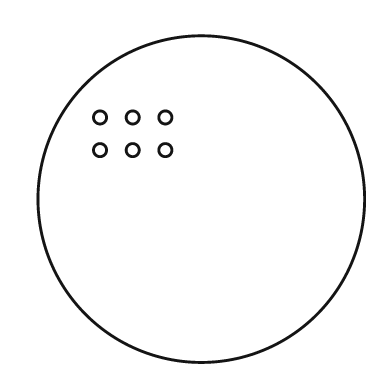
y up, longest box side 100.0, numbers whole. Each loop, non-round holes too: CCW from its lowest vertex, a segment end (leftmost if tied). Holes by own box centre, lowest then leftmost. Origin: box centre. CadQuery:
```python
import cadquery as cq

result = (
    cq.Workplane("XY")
    .moveTo(0.0, 0.0)
    .circle(50.0)
    .moveTo(-31.0, 15.0)
    .circle(2.0)
    .moveTo(-21.0, 15.0)
    .circle(2.0)
    .moveTo(-11.0, 15.0)
    .circle(2.0)
    .moveTo(-31.0, 25.0)
    .circle(2.0)
    .moveTo(-21.0, 25.0)
    .circle(2.0)
    .moveTo(-11.0, 25.0)
    .circle(2.0)
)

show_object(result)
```